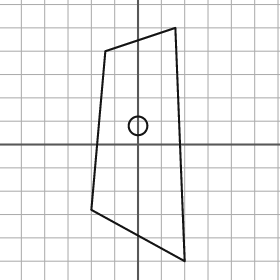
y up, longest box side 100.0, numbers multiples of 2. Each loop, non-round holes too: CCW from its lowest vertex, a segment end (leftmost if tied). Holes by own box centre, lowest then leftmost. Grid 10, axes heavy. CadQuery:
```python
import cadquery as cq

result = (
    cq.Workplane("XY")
    .moveTo(20.0, -50.0)
    .lineTo(16.0, 50.0)
    .lineTo(-14.0, 40.0)
    .lineTo(-20.0, -28.0)
    .close()
    .moveTo(0.0, 8.0)
    .circle(4.0)
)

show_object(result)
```